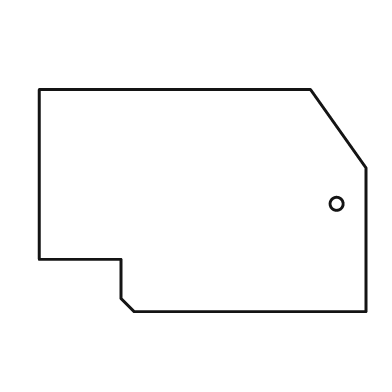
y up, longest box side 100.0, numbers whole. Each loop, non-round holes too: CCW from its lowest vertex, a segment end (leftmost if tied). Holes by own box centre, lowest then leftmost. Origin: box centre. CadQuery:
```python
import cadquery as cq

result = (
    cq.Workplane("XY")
    .moveTo(-21.0, -34.0)
    .lineTo(50.0, -34.0)
    .lineTo(50.0, 10.0)
    .lineTo(33.0, 34.0)
    .lineTo(-50.0, 34.0)
    .lineTo(-50.0, -18.0)
    .lineTo(-25.0, -18.0)
    .lineTo(-25.0, -30.0)
    .close()
    .moveTo(41.0, -1.0)
    .circle(2.0)
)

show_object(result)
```